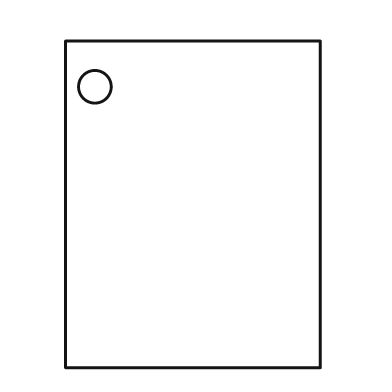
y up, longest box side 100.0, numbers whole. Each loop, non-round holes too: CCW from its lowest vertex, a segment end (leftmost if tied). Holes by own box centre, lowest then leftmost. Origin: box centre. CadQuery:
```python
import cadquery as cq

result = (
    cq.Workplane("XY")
    .moveTo(-39.0, -50.0)
    .lineTo(39.0, -50.0)
    .lineTo(39.0, 50.0)
    .lineTo(-39.0, 50.0)
    .close()
    .moveTo(-30.0, 36.0)
    .circle(5.0)
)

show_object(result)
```